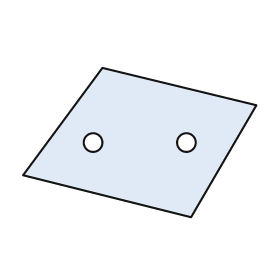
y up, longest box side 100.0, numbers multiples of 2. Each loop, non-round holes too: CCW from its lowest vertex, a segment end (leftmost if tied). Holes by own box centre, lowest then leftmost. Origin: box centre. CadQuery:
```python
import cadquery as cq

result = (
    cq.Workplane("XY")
    .moveTo(22.0, -32.0)
    .lineTo(50.0, 16.0)
    .lineTo(-16.0, 32.0)
    .lineTo(-50.0, -14.0)
    .close()
    .moveTo(-20.0, 0.0)
    .circle(4.0)
    .moveTo(20.0, 0.0)
    .circle(4.0)
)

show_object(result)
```